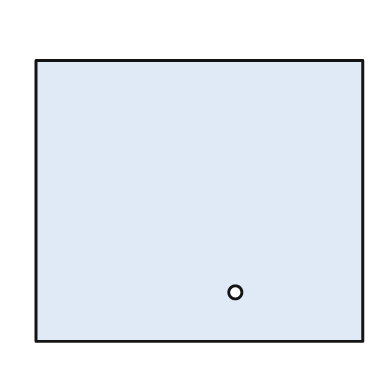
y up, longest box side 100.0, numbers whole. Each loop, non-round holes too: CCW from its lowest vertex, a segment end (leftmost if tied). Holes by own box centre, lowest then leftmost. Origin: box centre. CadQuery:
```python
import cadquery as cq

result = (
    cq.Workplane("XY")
    .moveTo(-50.0, -43.0)
    .lineTo(50.0, -43.0)
    .lineTo(50.0, 43.0)
    .lineTo(-50.0, 43.0)
    .close()
    .moveTo(11.0, -28.0)
    .circle(2.0)
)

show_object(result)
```